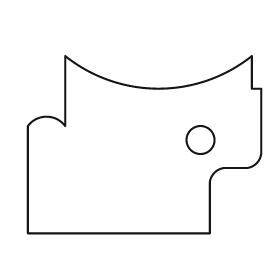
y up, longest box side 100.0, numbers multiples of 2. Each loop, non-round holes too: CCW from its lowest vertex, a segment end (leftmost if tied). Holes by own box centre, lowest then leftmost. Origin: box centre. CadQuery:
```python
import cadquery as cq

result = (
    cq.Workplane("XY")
    .moveTo(-50.0, -38.0)
    .lineTo(28.0, -38.0)
    .lineTo(28.0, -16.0)
    .threePointArc((30.0, -12.0), (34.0, -10.0))
    .lineTo(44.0, -10.0)
    .threePointArc((48.0, -8.0), (50.0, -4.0))
    .lineTo(50.0, 24.0)
    .lineTo(46.0, 24.0)
    .lineTo(46.0, 38.0)
    .threePointArc((6.0, 24.0), (-34.0, 38.0))
    .lineTo(-34.0, 8.0)
    .threePointArc((-42.0, 12.0), (-50.0, 8.0))
    .close()
    .moveTo(24.0, 2.0)
    .circle(6.0)
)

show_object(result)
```